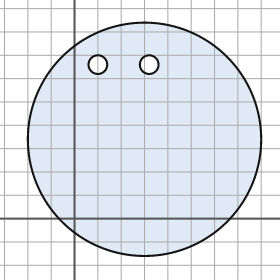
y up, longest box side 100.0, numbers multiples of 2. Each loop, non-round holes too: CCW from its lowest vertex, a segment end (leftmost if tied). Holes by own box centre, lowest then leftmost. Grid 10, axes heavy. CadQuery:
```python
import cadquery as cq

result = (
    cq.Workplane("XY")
    .moveTo(30.0, 34.0)
    .circle(50.0)
    .moveTo(10.0, 66.0)
    .circle(4.0)
    .moveTo(32.0, 66.0)
    .circle(4.0)
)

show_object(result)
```